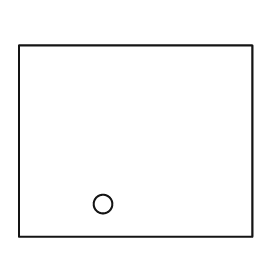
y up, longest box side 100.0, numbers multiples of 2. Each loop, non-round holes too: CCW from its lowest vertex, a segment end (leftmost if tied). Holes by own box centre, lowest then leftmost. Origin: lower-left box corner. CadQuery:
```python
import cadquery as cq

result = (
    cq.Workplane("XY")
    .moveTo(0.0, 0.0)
    .lineTo(100.0, 0.0)
    .lineTo(100.0, 82.0)
    .lineTo(0.0, 82.0)
    .close()
    .moveTo(36.0, 14.0)
    .circle(4.0)
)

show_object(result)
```